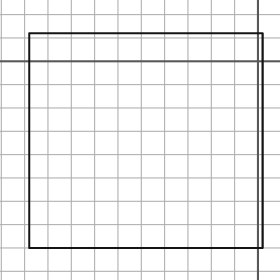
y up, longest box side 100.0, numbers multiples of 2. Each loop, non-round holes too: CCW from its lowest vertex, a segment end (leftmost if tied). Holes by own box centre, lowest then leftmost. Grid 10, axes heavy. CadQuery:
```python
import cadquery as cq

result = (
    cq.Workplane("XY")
    .moveTo(-98.0, -80.0)
    .lineTo(2.0, -80.0)
    .lineTo(2.0, 12.0)
    .lineTo(-98.0, 12.0)
    .close()
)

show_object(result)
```